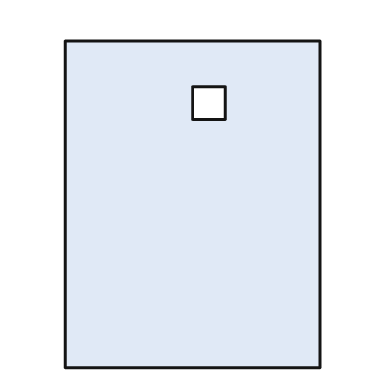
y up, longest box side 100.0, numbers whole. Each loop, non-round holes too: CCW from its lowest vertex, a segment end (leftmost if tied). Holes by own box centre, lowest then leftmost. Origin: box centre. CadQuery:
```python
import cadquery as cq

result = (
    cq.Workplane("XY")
    .moveTo(-39.0, -50.0)
    .lineTo(39.0, -50.0)
    .lineTo(39.0, 50.0)
    .lineTo(-39.0, 50.0)
    .close()
    .moveTo(0.0, 26.0)
    .lineTo(10.0, 26.0)
    .lineTo(10.0, 36.0)
    .lineTo(0.0, 36.0)
    .close()
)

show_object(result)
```